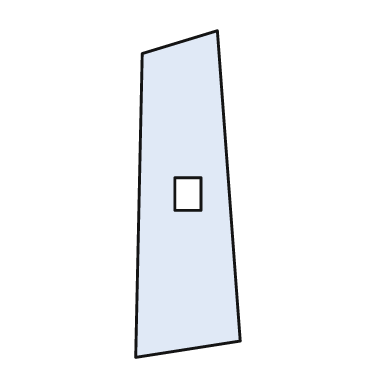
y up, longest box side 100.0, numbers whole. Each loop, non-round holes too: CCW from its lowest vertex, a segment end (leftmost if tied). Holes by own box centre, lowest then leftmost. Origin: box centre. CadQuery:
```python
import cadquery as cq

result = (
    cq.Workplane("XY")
    .moveTo(-16.0, -50.0)
    .lineTo(16.0, -45.0)
    .lineTo(9.0, 50.0)
    .lineTo(-14.0, 43.0)
    .close()
    .moveTo(-4.0, -5.0)
    .lineTo(4.0, -5.0)
    .lineTo(4.0, 5.0)
    .lineTo(-4.0, 5.0)
    .close()
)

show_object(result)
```